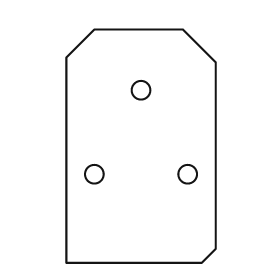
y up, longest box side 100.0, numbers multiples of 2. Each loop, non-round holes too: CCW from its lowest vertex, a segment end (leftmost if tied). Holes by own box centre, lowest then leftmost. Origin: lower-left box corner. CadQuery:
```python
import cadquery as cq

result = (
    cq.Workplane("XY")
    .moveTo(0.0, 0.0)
    .lineTo(58.0, 0.0)
    .lineTo(64.0, 6.0)
    .lineTo(64.0, 86.0)
    .lineTo(50.0, 100.0)
    .lineTo(12.0, 100.0)
    .lineTo(0.0, 88.0)
    .close()
    .moveTo(12.0, 38.0)
    .circle(4.0)
    .moveTo(52.0, 38.0)
    .circle(4.0)
    .moveTo(32.0, 74.0)
    .circle(4.0)
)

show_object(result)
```